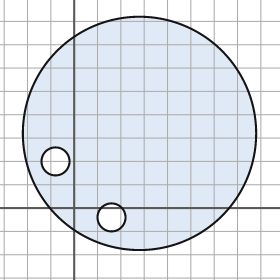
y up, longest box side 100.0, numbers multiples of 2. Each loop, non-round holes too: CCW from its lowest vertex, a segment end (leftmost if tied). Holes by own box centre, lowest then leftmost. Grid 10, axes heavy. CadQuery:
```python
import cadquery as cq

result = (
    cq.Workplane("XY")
    .moveTo(28.0, 32.0)
    .circle(50.0)
    .moveTo(16.0, -4.0)
    .circle(6.0)
    .moveTo(-8.0, 20.0)
    .circle(6.0)
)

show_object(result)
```